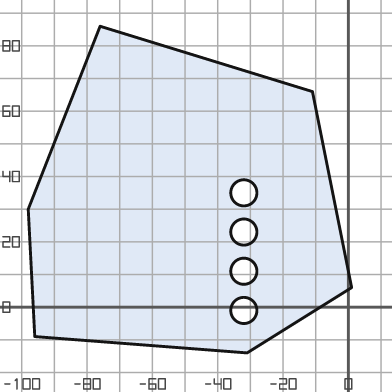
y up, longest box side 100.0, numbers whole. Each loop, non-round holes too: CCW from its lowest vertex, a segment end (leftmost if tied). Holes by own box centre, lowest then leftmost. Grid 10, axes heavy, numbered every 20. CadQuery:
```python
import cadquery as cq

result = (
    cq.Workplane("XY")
    .moveTo(-31.0, -14.0)
    .lineTo(1.0, 6.0)
    .lineTo(-11.0, 66.0)
    .lineTo(-76.0, 86.0)
    .lineTo(-98.0, 30.0)
    .lineTo(-96.0, -9.0)
    .close()
    .moveTo(-32.0, -1.0)
    .circle(4.0)
    .moveTo(-32.0, 11.0)
    .circle(4.0)
    .moveTo(-32.0, 23.0)
    .circle(4.0)
    .moveTo(-32.0, 35.0)
    .circle(4.0)
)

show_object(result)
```